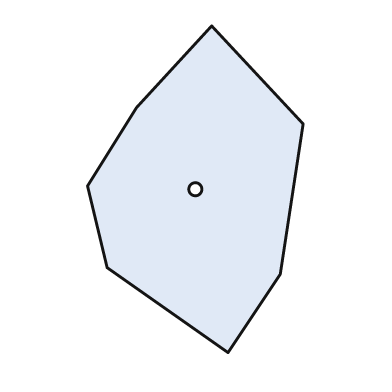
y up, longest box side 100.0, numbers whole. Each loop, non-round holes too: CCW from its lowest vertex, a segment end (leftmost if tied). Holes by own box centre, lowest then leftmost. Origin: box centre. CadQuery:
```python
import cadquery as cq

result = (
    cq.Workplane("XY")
    .moveTo(10.0, -50.0)
    .lineTo(26.0, -26.0)
    .lineTo(33.0, 20.0)
    .lineTo(5.0, 50.0)
    .lineTo(-18.0, 25.0)
    .lineTo(-33.0, 1.0)
    .lineTo(-27.0, -24.0)
    .close()
    .moveTo(0.0, 0.0)
    .circle(2.0)
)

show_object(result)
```